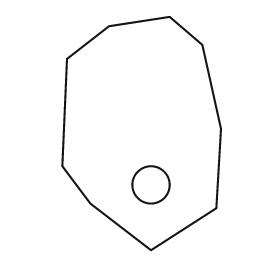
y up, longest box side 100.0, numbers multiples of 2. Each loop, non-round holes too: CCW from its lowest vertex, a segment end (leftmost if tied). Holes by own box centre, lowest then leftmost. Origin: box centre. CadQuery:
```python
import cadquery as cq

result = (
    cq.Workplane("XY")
    .moveTo(4.0, -50.0)
    .lineTo(32.0, -32.0)
    .lineTo(34.0, 2.0)
    .lineTo(26.0, 38.0)
    .lineTo(12.0, 50.0)
    .lineTo(-14.0, 46.0)
    .lineTo(-32.0, 32.0)
    .lineTo(-34.0, -14.0)
    .lineTo(-22.0, -30.0)
    .close()
    .moveTo(4.0, -22.0)
    .circle(8.0)
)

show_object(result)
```